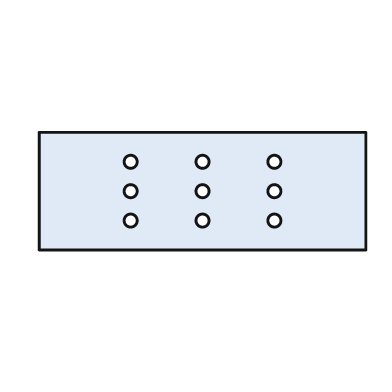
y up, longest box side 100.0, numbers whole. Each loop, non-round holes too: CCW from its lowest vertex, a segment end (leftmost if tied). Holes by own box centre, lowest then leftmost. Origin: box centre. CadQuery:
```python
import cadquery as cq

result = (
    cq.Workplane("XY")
    .moveTo(-50.0, -18.0)
    .lineTo(50.0, -18.0)
    .lineTo(50.0, 18.0)
    .lineTo(-50.0, 18.0)
    .close()
    .moveTo(-22.0, -9.0)
    .circle(2.0)
    .moveTo(0.0, -9.0)
    .circle(2.0)
    .moveTo(22.0, -9.0)
    .circle(2.0)
    .moveTo(-22.0, 0.0)
    .circle(2.0)
    .moveTo(0.0, 0.0)
    .circle(2.0)
    .moveTo(22.0, 0.0)
    .circle(2.0)
    .moveTo(-22.0, 9.0)
    .circle(2.0)
    .moveTo(0.0, 9.0)
    .circle(2.0)
    .moveTo(22.0, 9.0)
    .circle(2.0)
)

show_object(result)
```